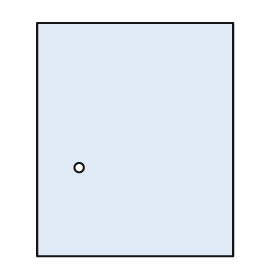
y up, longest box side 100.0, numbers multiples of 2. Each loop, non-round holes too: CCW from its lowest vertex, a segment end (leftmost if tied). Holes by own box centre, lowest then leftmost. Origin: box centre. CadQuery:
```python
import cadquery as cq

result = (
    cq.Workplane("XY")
    .moveTo(-42.0, -50.0)
    .lineTo(42.0, -50.0)
    .lineTo(42.0, 50.0)
    .lineTo(-42.0, 50.0)
    .close()
    .moveTo(-24.0, -12.0)
    .circle(2.0)
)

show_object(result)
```